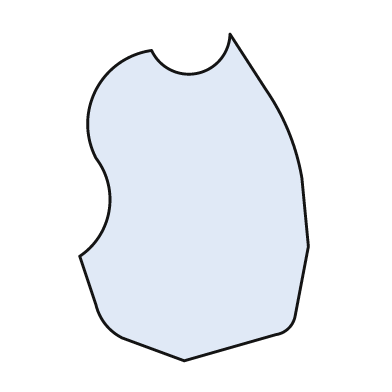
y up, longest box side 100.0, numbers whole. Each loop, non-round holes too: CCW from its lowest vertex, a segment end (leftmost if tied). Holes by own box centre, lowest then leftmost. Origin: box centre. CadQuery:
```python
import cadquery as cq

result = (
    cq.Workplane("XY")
    .moveTo(-3.0, -50.0)
    .lineTo(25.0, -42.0)
    .threePointArc((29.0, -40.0), (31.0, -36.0))
    .lineTo(35.0, -15.0)
    .lineTo(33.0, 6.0)
    .threePointArc((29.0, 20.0), (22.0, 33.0))
    .lineTo(11.0, 50.0)
    .threePointArc((1.0, 38.0), (-13.0, 45.0))
    .threePointArc((-30.0, 33.0), (-30.0, 12.0))
    .threePointArc((-26.0, -4.0), (-35.0, -18.0))
    .lineTo(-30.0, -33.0)
    .threePointArc((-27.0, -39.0), (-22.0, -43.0))
    .close()
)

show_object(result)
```